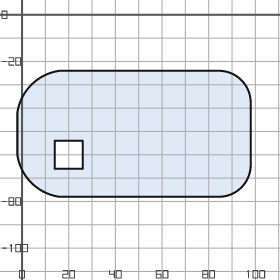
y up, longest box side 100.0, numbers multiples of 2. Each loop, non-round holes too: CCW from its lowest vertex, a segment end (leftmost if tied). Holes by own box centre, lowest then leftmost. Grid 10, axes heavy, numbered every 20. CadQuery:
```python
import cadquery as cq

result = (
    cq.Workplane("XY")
    .moveTo(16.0, -78.0)
    .lineTo(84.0, -78.0)
    .threePointArc((94.0, -74.0), (98.0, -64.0))
    .lineTo(98.0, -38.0)
    .threePointArc((94.0, -28.0), (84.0, -24.0))
    .lineTo(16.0, -24.0)
    .threePointArc((4.0, -30.0), (-2.0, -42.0))
    .lineTo(-2.0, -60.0)
    .threePointArc((4.0, -72.0), (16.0, -78.0))
    .close()
    .moveTo(14.0, -66.0)
    .lineTo(26.0, -66.0)
    .lineTo(26.0, -54.0)
    .lineTo(14.0, -54.0)
    .close()
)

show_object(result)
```